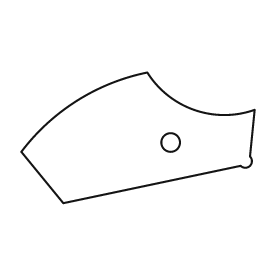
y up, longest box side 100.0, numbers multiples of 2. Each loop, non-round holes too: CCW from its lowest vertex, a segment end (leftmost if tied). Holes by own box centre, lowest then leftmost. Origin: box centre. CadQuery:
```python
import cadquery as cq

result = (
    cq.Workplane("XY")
    .moveTo(-32.0, -28.0)
    .lineTo(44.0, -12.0)
    .threePointArc((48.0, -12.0), (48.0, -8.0))
    .lineTo(50.0, 12.0)
    .threePointArc((24.0, 12.0), (4.0, 28.0))
    .threePointArc((-26.0, 16.0), (-50.0, -6.0))
    .close()
    .moveTo(14.0, -2.0)
    .circle(4.0)
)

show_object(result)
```